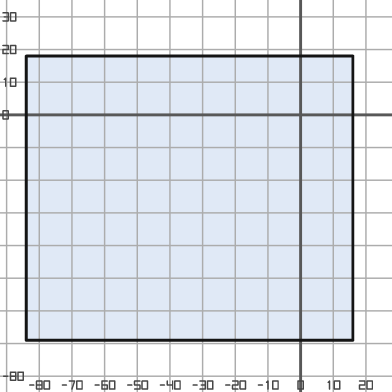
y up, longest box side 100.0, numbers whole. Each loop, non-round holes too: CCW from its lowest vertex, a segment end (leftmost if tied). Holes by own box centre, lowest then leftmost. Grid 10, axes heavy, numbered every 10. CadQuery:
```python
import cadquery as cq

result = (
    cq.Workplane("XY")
    .moveTo(-84.0, -69.0)
    .lineTo(16.0, -69.0)
    .lineTo(16.0, 18.0)
    .lineTo(-84.0, 18.0)
    .close()
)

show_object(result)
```